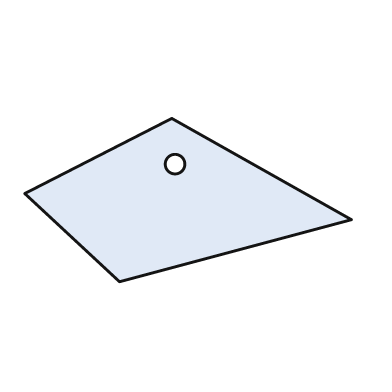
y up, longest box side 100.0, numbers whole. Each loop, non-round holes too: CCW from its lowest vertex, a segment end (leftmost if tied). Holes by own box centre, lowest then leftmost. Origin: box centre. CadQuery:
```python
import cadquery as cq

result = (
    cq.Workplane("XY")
    .moveTo(-21.0, -25.0)
    .lineTo(50.0, -6.0)
    .lineTo(-5.0, 25.0)
    .lineTo(-50.0, 2.0)
    .close()
    .moveTo(-4.0, 11.0)
    .circle(3.0)
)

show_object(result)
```